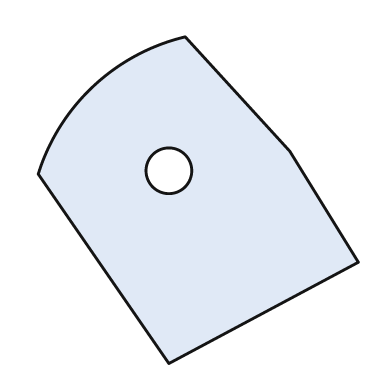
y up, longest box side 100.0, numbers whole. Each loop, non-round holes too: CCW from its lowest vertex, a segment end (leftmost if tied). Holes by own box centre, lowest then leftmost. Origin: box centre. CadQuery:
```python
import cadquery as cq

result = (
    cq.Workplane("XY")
    .moveTo(-9.0, -50.0)
    .lineTo(49.0, -19.0)
    .lineTo(28.0, 15.0)
    .lineTo(-4.0, 50.0)
    .threePointArc((-32.0, 35.0), (-49.0, 8.0))
    .close()
    .moveTo(-9.0, 9.0)
    .circle(7.0)
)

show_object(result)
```